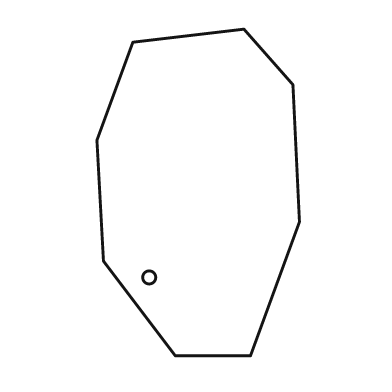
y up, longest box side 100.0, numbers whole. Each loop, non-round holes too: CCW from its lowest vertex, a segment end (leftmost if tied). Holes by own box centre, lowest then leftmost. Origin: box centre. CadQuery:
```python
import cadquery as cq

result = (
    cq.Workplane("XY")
    .moveTo(-7.0, -50.0)
    .lineTo(16.0, -50.0)
    .lineTo(31.0, -9.0)
    .lineTo(29.0, 33.0)
    .lineTo(14.0, 50.0)
    .lineTo(-20.0, 46.0)
    .lineTo(-31.0, 16.0)
    .lineTo(-29.0, -21.0)
    .close()
    .moveTo(-15.0, -26.0)
    .circle(2.0)
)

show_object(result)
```